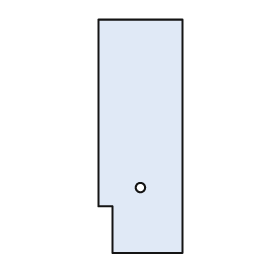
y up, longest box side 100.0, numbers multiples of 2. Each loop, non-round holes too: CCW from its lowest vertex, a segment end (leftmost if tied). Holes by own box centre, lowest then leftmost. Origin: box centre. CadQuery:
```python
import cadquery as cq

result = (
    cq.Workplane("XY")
    .moveTo(-12.0, -50.0)
    .lineTo(18.0, -50.0)
    .lineTo(18.0, 50.0)
    .lineTo(-18.0, 50.0)
    .lineTo(-18.0, -30.0)
    .lineTo(-12.0, -30.0)
    .close()
    .moveTo(0.0, -22.0)
    .circle(2.0)
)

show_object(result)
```